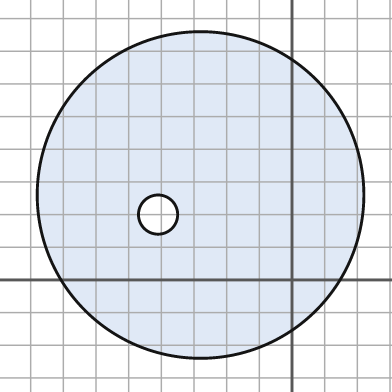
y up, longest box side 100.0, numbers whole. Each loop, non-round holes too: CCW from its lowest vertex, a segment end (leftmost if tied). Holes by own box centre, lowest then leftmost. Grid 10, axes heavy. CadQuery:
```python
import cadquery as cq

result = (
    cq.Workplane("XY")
    .moveTo(-28.0, 26.0)
    .circle(50.0)
    .moveTo(-41.0, 20.0)
    .circle(6.0)
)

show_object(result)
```